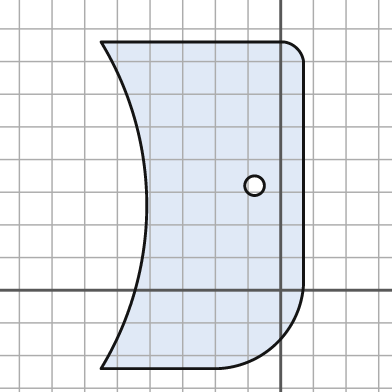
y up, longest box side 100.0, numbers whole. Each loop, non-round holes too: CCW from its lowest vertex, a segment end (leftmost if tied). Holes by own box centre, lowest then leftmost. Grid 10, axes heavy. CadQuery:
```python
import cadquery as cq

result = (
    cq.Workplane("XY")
    .moveTo(-55.0, -24.0)
    .lineTo(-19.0, -24.0)
    .threePointArc((-1.0, -16.0), (7.0, 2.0))
    .lineTo(7.0, 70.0)
    .threePointArc((5.0, 74.0), (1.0, 76.0))
    .lineTo(-55.0, 76.0)
    .threePointArc((-41.0, 26.0), (-55.0, -24.0))
    .close()
    .moveTo(-8.0, 32.0)
    .circle(3.0)
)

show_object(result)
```